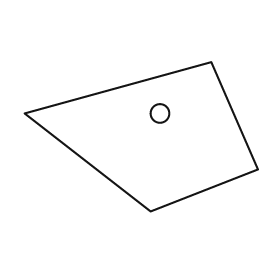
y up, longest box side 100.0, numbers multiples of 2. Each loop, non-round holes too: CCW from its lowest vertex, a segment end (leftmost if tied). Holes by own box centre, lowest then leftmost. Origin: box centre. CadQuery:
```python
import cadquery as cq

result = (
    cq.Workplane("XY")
    .moveTo(4.0, -32.0)
    .lineTo(50.0, -14.0)
    .lineTo(30.0, 32.0)
    .lineTo(-50.0, 10.0)
    .close()
    .moveTo(8.0, 10.0)
    .circle(4.0)
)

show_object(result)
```